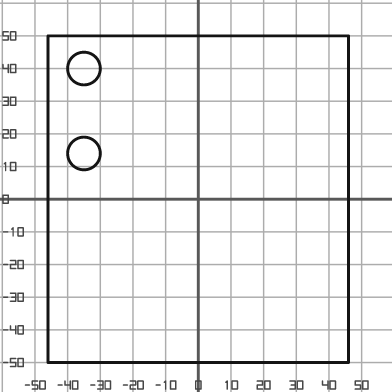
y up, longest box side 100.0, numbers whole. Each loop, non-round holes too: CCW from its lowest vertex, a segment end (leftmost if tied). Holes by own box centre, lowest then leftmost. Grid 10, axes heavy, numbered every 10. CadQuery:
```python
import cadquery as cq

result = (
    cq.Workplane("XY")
    .moveTo(-46.0, -50.0)
    .lineTo(46.0, -50.0)
    .lineTo(46.0, 50.0)
    .lineTo(-46.0, 50.0)
    .close()
    .moveTo(-35.0, 14.0)
    .circle(5.0)
    .moveTo(-35.0, 40.0)
    .circle(5.0)
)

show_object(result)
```